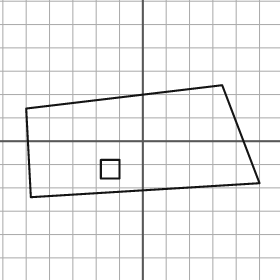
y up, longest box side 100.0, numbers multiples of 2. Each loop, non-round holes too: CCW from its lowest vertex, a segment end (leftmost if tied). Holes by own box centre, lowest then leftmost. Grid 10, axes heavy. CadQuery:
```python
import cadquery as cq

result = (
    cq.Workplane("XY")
    .moveTo(-48.0, -24.0)
    .lineTo(50.0, -18.0)
    .lineTo(34.0, 24.0)
    .lineTo(-50.0, 14.0)
    .close()
    .moveTo(-18.0, -16.0)
    .lineTo(-10.0, -16.0)
    .lineTo(-10.0, -8.0)
    .lineTo(-18.0, -8.0)
    .close()
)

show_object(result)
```